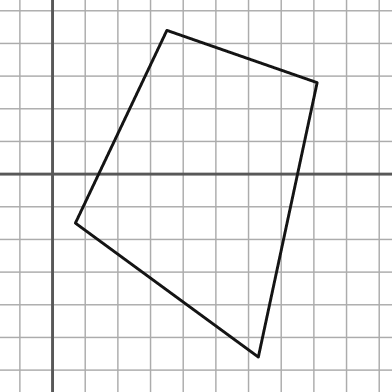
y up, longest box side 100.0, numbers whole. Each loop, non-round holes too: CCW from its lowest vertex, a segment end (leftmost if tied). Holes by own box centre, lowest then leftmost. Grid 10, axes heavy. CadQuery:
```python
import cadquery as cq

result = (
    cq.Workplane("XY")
    .moveTo(63.0, -56.0)
    .lineTo(81.0, 28.0)
    .lineTo(35.0, 44.0)
    .lineTo(7.0, -15.0)
    .close()
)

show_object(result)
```